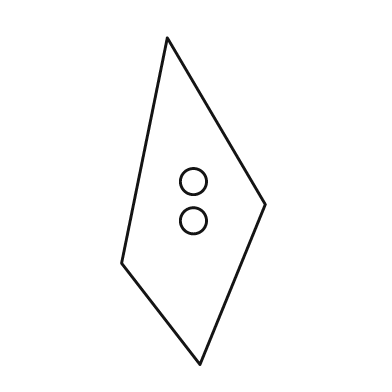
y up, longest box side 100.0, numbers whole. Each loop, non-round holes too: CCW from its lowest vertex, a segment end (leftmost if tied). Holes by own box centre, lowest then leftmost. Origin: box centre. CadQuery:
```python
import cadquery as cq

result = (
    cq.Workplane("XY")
    .moveTo(2.0, -50.0)
    .lineTo(22.0, -1.0)
    .lineTo(-8.0, 50.0)
    .lineTo(-22.0, -19.0)
    .close()
    .moveTo(0.0, -6.0)
    .circle(4.0)
    .moveTo(0.0, 6.0)
    .circle(4.0)
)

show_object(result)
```